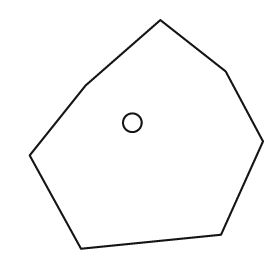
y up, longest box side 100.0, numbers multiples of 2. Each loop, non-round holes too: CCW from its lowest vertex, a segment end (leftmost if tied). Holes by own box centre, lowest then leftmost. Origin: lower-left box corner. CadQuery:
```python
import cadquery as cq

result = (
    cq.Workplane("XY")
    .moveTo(22.0, 0.0)
    .lineTo(82.0, 6.0)
    .lineTo(100.0, 46.0)
    .lineTo(84.0, 76.0)
    .lineTo(56.0, 98.0)
    .lineTo(24.0, 70.0)
    .lineTo(0.0, 40.0)
    .close()
    .moveTo(44.0, 54.0)
    .circle(4.0)
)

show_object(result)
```